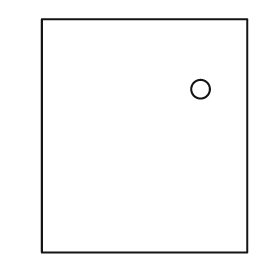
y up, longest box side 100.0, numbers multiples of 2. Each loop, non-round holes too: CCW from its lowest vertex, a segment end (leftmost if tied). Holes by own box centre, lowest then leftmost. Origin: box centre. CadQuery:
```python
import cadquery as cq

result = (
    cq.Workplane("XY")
    .moveTo(-44.0, -50.0)
    .lineTo(44.0, -50.0)
    .lineTo(44.0, 50.0)
    .lineTo(-44.0, 50.0)
    .close()
    .moveTo(24.0, 20.0)
    .circle(4.0)
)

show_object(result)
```